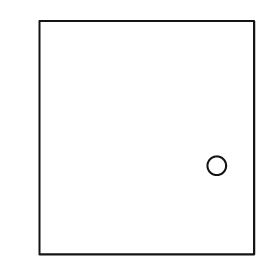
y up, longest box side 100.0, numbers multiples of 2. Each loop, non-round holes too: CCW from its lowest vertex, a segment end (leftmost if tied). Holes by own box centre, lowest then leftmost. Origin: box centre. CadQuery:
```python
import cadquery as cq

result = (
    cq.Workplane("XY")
    .moveTo(-46.0, -50.0)
    .lineTo(46.0, -50.0)
    .lineTo(46.0, 50.0)
    .lineTo(-46.0, 50.0)
    .close()
    .moveTo(30.0, -12.0)
    .circle(4.0)
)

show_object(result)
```